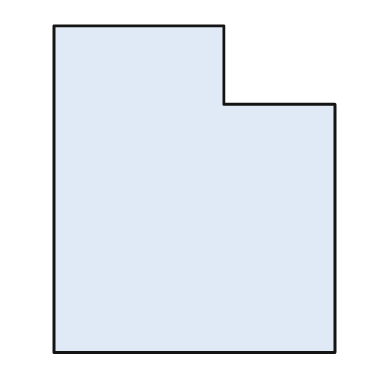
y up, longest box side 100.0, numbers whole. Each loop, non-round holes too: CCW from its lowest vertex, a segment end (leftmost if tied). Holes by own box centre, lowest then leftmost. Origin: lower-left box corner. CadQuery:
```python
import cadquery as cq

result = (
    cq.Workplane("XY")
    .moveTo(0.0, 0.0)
    .lineTo(86.0, 0.0)
    .lineTo(86.0, 76.0)
    .lineTo(52.0, 76.0)
    .lineTo(52.0, 100.0)
    .lineTo(0.0, 100.0)
    .close()
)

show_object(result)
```